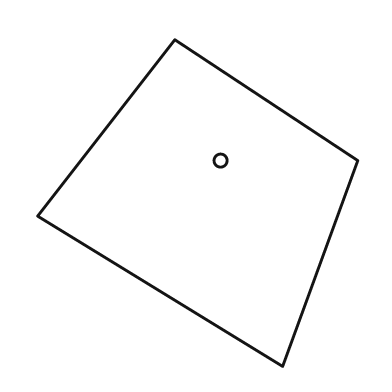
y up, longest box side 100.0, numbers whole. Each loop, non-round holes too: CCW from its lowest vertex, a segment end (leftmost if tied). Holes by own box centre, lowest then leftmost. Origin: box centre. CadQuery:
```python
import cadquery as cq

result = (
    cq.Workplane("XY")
    .moveTo(26.0, -50.0)
    .lineTo(49.0, 13.0)
    .lineTo(-7.0, 50.0)
    .lineTo(-49.0, -4.0)
    .close()
    .moveTo(7.0, 13.0)
    .circle(2.0)
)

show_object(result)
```